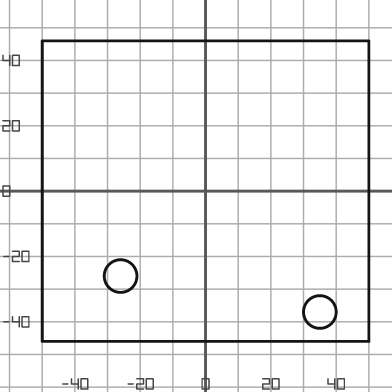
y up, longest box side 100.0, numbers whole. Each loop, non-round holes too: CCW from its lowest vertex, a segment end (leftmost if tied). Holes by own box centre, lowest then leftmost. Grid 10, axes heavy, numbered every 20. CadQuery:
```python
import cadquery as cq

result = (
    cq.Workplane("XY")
    .moveTo(-50.0, -46.0)
    .lineTo(50.0, -46.0)
    .lineTo(50.0, 46.0)
    .lineTo(-50.0, 46.0)
    .close()
    .moveTo(35.0, -37.0)
    .circle(5.0)
    .moveTo(-26.0, -26.0)
    .circle(5.0)
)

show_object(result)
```